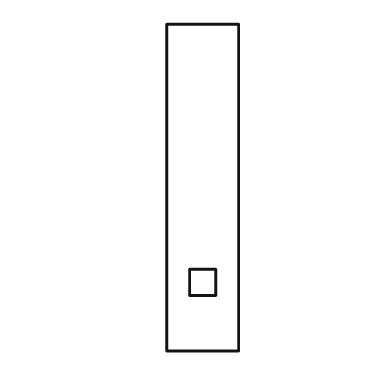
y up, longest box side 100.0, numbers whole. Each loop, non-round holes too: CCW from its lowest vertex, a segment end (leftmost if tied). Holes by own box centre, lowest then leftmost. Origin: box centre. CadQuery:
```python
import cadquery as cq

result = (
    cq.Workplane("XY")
    .moveTo(-11.0, -50.0)
    .lineTo(11.0, -50.0)
    .lineTo(11.0, 50.0)
    .lineTo(-11.0, 50.0)
    .close()
    .moveTo(-4.0, -33.0)
    .lineTo(4.0, -33.0)
    .lineTo(4.0, -25.0)
    .lineTo(-4.0, -25.0)
    .close()
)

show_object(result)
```